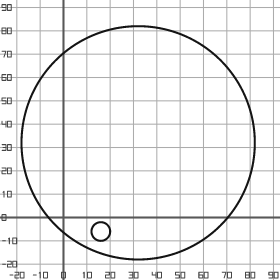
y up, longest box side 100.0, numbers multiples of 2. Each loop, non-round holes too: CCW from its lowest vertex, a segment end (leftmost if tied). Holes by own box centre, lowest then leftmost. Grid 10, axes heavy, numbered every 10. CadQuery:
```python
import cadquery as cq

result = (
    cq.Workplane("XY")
    .moveTo(32.0, 32.0)
    .circle(50.0)
    .moveTo(16.0, -6.0)
    .circle(4.0)
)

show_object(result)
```